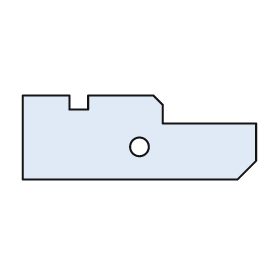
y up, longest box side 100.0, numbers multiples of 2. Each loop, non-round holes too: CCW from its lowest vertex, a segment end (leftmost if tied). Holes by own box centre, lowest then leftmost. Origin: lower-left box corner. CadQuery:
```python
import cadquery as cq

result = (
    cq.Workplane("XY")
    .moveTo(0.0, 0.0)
    .lineTo(92.0, 0.0)
    .lineTo(100.0, 8.0)
    .lineTo(100.0, 24.0)
    .lineTo(60.0, 24.0)
    .lineTo(60.0, 32.0)
    .lineTo(56.0, 36.0)
    .lineTo(28.0, 36.0)
    .lineTo(28.0, 30.0)
    .lineTo(20.0, 30.0)
    .lineTo(20.0, 36.0)
    .lineTo(0.0, 36.0)
    .close()
    .moveTo(50.0, 14.0)
    .circle(4.0)
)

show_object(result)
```